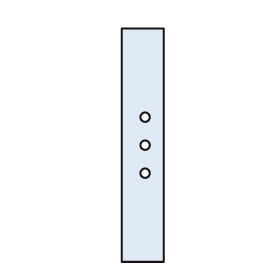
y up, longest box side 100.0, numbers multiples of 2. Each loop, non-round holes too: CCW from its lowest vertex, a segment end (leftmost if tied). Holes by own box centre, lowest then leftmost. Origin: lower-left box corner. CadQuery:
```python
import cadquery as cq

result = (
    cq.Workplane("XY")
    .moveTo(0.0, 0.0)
    .lineTo(18.0, 0.0)
    .lineTo(18.0, 100.0)
    .lineTo(0.0, 100.0)
    .close()
    .moveTo(10.0, 38.0)
    .circle(2.0)
    .moveTo(10.0, 50.0)
    .circle(2.0)
    .moveTo(10.0, 62.0)
    .circle(2.0)
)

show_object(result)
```